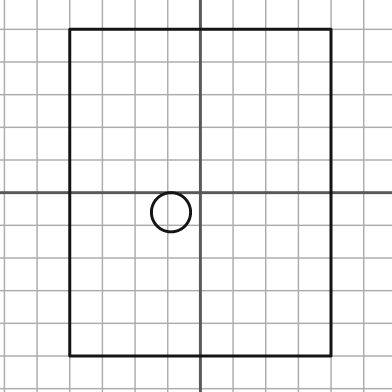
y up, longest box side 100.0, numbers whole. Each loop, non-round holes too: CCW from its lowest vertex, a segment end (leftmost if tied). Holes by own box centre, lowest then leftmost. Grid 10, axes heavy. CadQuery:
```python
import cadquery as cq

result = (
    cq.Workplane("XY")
    .moveTo(-40.0, -50.0)
    .lineTo(40.0, -50.0)
    .lineTo(40.0, 50.0)
    .lineTo(-40.0, 50.0)
    .close()
    .moveTo(-9.0, -6.0)
    .circle(6.0)
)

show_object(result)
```